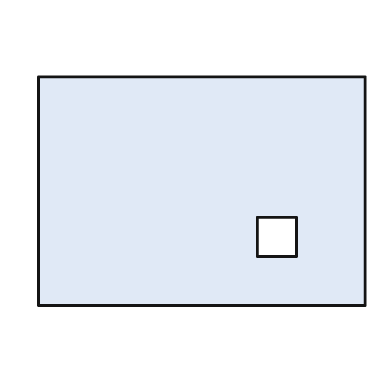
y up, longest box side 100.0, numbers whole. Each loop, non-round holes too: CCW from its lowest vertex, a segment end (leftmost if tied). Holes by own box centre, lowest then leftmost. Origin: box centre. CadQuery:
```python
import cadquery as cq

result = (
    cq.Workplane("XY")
    .moveTo(-50.0, -35.0)
    .lineTo(50.0, -35.0)
    .lineTo(50.0, 35.0)
    .lineTo(-50.0, 35.0)
    .close()
    .moveTo(17.0, -20.0)
    .lineTo(29.0, -20.0)
    .lineTo(29.0, -8.0)
    .lineTo(17.0, -8.0)
    .close()
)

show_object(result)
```